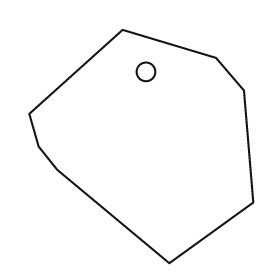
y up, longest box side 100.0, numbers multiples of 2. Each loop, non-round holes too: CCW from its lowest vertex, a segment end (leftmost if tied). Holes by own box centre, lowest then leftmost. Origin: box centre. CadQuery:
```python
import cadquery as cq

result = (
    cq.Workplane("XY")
    .moveTo(12.0, -50.0)
    .lineTo(48.0, -24.0)
    .lineTo(44.0, 24.0)
    .lineTo(32.0, 38.0)
    .lineTo(-8.0, 50.0)
    .lineTo(-48.0, 14.0)
    .lineTo(-44.0, 0.0)
    .lineTo(-36.0, -10.0)
    .close()
    .moveTo(2.0, 32.0)
    .circle(4.0)
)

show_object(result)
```